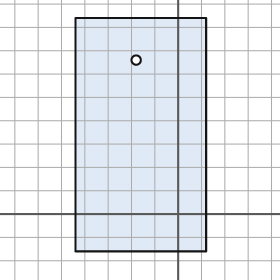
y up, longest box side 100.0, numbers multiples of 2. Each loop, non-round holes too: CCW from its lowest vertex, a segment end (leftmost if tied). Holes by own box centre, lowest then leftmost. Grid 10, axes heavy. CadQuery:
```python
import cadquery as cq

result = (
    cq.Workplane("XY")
    .moveTo(-44.0, -16.0)
    .lineTo(12.0, -16.0)
    .lineTo(12.0, 84.0)
    .lineTo(-44.0, 84.0)
    .close()
    .moveTo(-18.0, 66.0)
    .circle(2.0)
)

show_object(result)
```